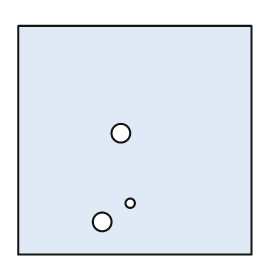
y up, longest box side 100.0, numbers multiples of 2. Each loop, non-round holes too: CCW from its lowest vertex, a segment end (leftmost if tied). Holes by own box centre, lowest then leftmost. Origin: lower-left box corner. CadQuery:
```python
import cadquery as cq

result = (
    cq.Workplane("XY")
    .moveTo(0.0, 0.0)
    .lineTo(100.0, 0.0)
    .lineTo(100.0, 98.0)
    .lineTo(0.0, 98.0)
    .close()
    .moveTo(36.0, 14.0)
    .circle(4.0)
    .moveTo(48.0, 22.0)
    .circle(2.0)
    .moveTo(44.0, 52.0)
    .circle(4.0)
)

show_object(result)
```